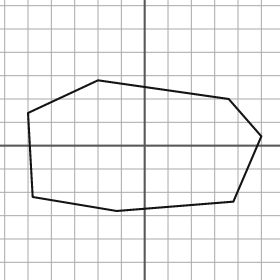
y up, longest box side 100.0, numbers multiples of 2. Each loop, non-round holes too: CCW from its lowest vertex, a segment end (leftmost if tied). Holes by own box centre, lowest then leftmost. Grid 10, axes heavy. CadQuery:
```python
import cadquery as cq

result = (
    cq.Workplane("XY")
    .moveTo(-12.0, -28.0)
    .lineTo(38.0, -24.0)
    .lineTo(50.0, 4.0)
    .lineTo(36.0, 20.0)
    .lineTo(-20.0, 28.0)
    .lineTo(-50.0, 14.0)
    .lineTo(-48.0, -22.0)
    .close()
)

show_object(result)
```